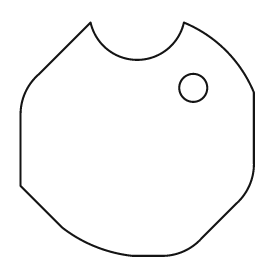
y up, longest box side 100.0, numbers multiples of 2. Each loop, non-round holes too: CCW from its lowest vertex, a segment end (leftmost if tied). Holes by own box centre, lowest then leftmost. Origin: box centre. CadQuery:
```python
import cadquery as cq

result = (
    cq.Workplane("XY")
    .moveTo(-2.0, -50.0)
    .lineTo(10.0, -50.0)
    .threePointArc((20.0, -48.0), (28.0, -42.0))
    .lineTo(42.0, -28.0)
    .threePointArc((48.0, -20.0), (50.0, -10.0))
    .lineTo(50.0, 20.0)
    .threePointArc((38.0, 38.0), (20.0, 50.0))
    .threePointArc((0.0, 34.0), (-20.0, 50.0))
    .lineTo(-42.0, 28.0)
    .threePointArc((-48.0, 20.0), (-50.0, 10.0))
    .lineTo(-50.0, -20.0)
    .lineTo(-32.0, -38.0)
    .threePointArc((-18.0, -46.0), (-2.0, -50.0))
    .close()
    .moveTo(24.0, 22.0)
    .circle(6.0)
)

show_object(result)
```